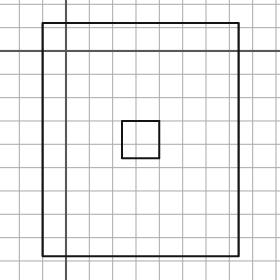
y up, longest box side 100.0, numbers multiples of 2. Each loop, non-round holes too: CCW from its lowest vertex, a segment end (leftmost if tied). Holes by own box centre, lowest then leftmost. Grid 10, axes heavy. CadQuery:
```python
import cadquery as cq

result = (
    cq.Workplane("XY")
    .moveTo(-10.0, -88.0)
    .lineTo(74.0, -88.0)
    .lineTo(74.0, 12.0)
    .lineTo(-10.0, 12.0)
    .close()
    .moveTo(24.0, -46.0)
    .lineTo(40.0, -46.0)
    .lineTo(40.0, -30.0)
    .lineTo(24.0, -30.0)
    .close()
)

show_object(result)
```